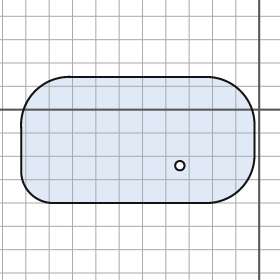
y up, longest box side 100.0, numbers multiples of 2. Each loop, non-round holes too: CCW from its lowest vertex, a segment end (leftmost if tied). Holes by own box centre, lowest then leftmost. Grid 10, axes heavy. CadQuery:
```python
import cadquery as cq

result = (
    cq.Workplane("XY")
    .moveTo(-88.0, -40.0)
    .lineTo(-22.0, -40.0)
    .threePointArc((-8.0, -34.0), (-2.0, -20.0))
    .lineTo(-2.0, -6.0)
    .threePointArc((-8.0, 8.0), (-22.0, 14.0))
    .lineTo(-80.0, 14.0)
    .threePointArc((-96.0, 8.0), (-102.0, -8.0))
    .lineTo(-102.0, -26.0)
    .threePointArc((-98.0, -36.0), (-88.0, -40.0))
    .close()
    .moveTo(-34.0, -24.0)
    .circle(2.0)
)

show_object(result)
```